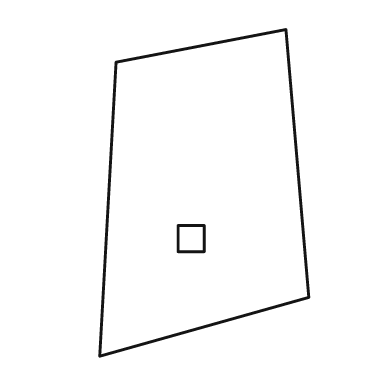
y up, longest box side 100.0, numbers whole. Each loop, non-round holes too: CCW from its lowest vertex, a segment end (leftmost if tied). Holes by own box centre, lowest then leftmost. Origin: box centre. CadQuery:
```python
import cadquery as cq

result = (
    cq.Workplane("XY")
    .moveTo(-32.0, -50.0)
    .lineTo(32.0, -32.0)
    .lineTo(25.0, 50.0)
    .lineTo(-27.0, 40.0)
    .close()
    .moveTo(-8.0, -18.0)
    .lineTo(0.0, -18.0)
    .lineTo(0.0, -10.0)
    .lineTo(-8.0, -10.0)
    .close()
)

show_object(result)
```